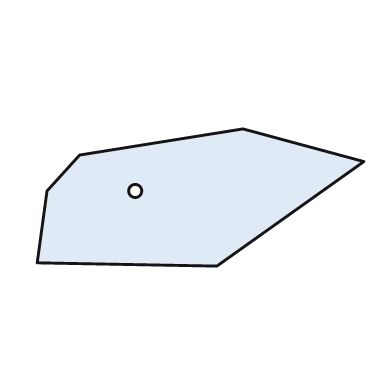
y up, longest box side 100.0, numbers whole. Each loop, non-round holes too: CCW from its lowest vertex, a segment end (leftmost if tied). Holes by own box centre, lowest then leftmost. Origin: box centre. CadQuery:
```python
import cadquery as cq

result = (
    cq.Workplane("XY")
    .moveTo(5.0, -21.0)
    .lineTo(50.0, 11.0)
    .lineTo(13.0, 21.0)
    .lineTo(-37.0, 13.0)
    .lineTo(-47.0, 2.0)
    .lineTo(-50.0, -20.0)
    .close()
    .moveTo(-20.0, 2.0)
    .circle(2.0)
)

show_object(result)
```